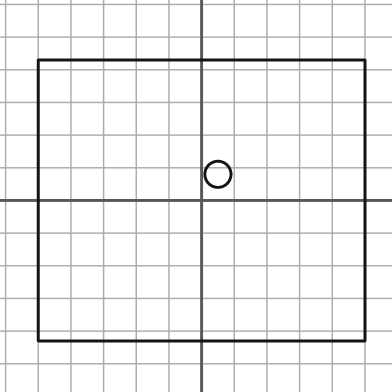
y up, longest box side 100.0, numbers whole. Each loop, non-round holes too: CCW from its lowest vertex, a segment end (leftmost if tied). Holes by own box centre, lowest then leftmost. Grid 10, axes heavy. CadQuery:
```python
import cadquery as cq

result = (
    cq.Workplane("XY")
    .moveTo(-50.0, -43.0)
    .lineTo(50.0, -43.0)
    .lineTo(50.0, 43.0)
    .lineTo(-50.0, 43.0)
    .close()
    .moveTo(5.0, 8.0)
    .circle(4.0)
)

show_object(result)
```